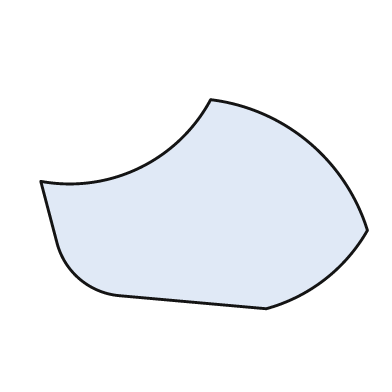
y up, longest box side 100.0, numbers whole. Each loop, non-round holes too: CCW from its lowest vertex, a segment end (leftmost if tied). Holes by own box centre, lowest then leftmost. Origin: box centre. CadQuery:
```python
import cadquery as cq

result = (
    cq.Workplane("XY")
    .moveTo(19.0, -32.0)
    .threePointArc((37.0, -23.0), (50.0, -8.0))
    .threePointArc((32.0, 19.0), (2.0, 32.0))
    .threePointArc((-20.0, 11.0), (-50.0, 7.0))
    .lineTo(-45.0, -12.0)
    .threePointArc((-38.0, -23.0), (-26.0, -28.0))
    .close()
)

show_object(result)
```